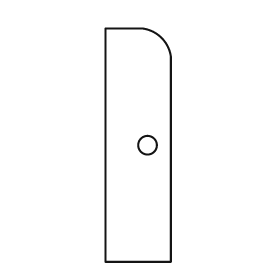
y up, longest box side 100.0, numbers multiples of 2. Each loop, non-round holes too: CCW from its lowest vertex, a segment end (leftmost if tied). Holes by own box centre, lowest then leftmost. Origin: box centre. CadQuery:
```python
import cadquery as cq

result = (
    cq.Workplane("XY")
    .moveTo(-14.0, -50.0)
    .lineTo(14.0, -50.0)
    .lineTo(14.0, 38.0)
    .threePointArc((10.0, 46.0), (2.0, 50.0))
    .lineTo(-14.0, 50.0)
    .close()
    .moveTo(4.0, 0.0)
    .circle(4.0)
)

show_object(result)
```